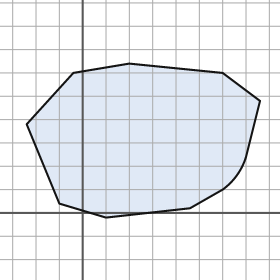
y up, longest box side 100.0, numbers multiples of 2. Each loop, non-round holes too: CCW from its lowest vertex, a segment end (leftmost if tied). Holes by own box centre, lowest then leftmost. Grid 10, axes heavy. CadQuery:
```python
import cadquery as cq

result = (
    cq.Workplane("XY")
    .moveTo(10.0, -2.0)
    .lineTo(46.0, 2.0)
    .lineTo(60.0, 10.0)
    .threePointArc((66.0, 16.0), (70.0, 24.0))
    .lineTo(76.0, 48.0)
    .lineTo(60.0, 60.0)
    .lineTo(20.0, 64.0)
    .lineTo(-4.0, 60.0)
    .lineTo(-24.0, 38.0)
    .lineTo(-10.0, 4.0)
    .close()
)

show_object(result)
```